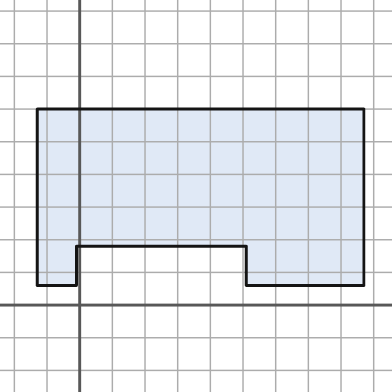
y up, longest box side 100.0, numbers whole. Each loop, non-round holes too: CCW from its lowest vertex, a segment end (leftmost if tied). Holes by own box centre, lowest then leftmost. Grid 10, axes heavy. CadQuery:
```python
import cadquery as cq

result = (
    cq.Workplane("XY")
    .moveTo(-13.0, 6.0)
    .lineTo(-1.0, 6.0)
    .lineTo(-1.0, 18.0)
    .lineTo(51.0, 18.0)
    .lineTo(51.0, 6.0)
    .lineTo(87.0, 6.0)
    .lineTo(87.0, 60.0)
    .lineTo(-13.0, 60.0)
    .close()
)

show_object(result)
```